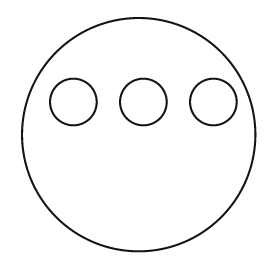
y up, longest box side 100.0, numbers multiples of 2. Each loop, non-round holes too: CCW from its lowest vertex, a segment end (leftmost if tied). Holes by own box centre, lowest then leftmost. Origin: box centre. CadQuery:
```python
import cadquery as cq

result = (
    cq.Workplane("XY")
    .moveTo(0.0, 0.0)
    .circle(50.0)
    .moveTo(-28.0, 14.0)
    .circle(10.0)
    .moveTo(2.0, 14.0)
    .circle(10.0)
    .moveTo(32.0, 14.0)
    .circle(10.0)
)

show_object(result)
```